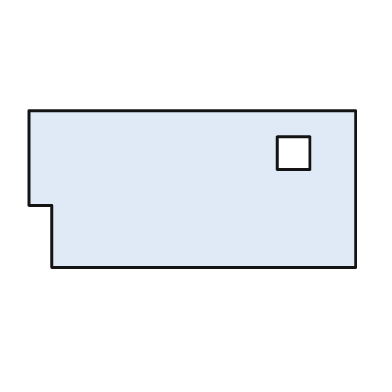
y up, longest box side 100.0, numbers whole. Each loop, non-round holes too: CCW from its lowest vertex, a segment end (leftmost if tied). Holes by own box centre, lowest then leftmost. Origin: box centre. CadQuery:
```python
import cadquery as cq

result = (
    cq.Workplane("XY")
    .moveTo(-43.0, -24.0)
    .lineTo(50.0, -24.0)
    .lineTo(50.0, 24.0)
    .lineTo(-50.0, 24.0)
    .lineTo(-50.0, -5.0)
    .lineTo(-43.0, -5.0)
    .close()
    .moveTo(26.0, 6.0)
    .lineTo(36.0, 6.0)
    .lineTo(36.0, 16.0)
    .lineTo(26.0, 16.0)
    .close()
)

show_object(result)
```